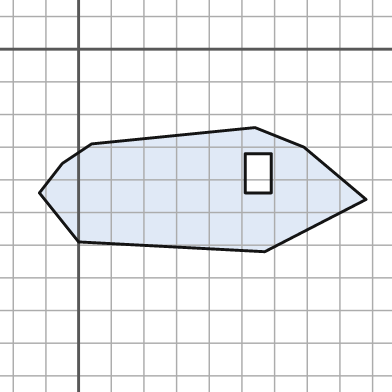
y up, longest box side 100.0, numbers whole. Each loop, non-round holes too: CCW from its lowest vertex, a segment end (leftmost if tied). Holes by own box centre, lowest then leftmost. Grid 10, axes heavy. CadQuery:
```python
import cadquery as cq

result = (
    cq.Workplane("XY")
    .moveTo(57.0, -62.0)
    .lineTo(88.0, -46.0)
    .lineTo(69.0, -30.0)
    .lineTo(54.0, -24.0)
    .lineTo(4.0, -29.0)
    .lineTo(-5.0, -35.0)
    .lineTo(-12.0, -44.0)
    .lineTo(0.0, -59.0)
    .close()
    .moveTo(51.0, -44.0)
    .lineTo(59.0, -44.0)
    .lineTo(59.0, -32.0)
    .lineTo(51.0, -32.0)
    .close()
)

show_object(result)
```